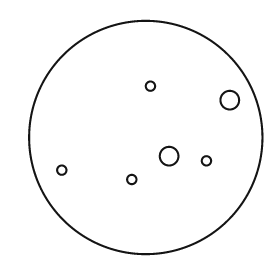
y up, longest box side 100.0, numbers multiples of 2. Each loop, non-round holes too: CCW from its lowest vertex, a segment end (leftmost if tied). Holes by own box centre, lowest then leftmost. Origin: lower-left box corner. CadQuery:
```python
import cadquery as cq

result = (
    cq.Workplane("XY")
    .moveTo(50.0, 50.0)
    .circle(50.0)
    .moveTo(44.0, 32.0)
    .circle(2.0)
    .moveTo(14.0, 36.0)
    .circle(2.0)
    .moveTo(76.0, 40.0)
    .circle(2.0)
    .moveTo(60.0, 42.0)
    .circle(4.0)
    .moveTo(86.0, 66.0)
    .circle(4.0)
    .moveTo(52.0, 72.0)
    .circle(2.0)
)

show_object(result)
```